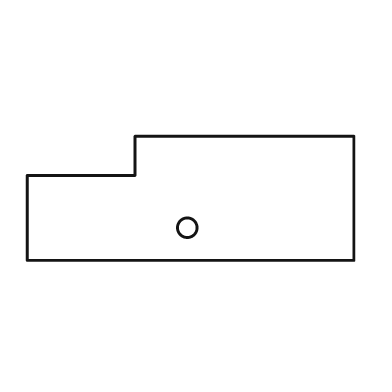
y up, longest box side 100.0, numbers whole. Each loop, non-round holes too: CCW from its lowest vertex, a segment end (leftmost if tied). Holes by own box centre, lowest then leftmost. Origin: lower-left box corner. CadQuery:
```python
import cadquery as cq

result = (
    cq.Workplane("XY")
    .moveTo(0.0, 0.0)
    .lineTo(100.0, 0.0)
    .lineTo(100.0, 38.0)
    .lineTo(33.0, 38.0)
    .lineTo(33.0, 26.0)
    .lineTo(0.0, 26.0)
    .close()
    .moveTo(49.0, 10.0)
    .circle(3.0)
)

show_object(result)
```